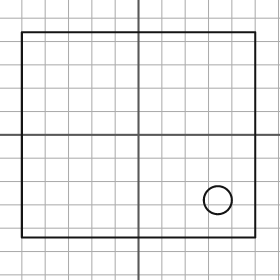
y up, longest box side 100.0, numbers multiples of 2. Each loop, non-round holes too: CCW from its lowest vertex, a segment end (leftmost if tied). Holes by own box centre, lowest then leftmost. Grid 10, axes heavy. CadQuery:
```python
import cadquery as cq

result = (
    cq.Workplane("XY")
    .moveTo(-50.0, -44.0)
    .lineTo(50.0, -44.0)
    .lineTo(50.0, 44.0)
    .lineTo(-50.0, 44.0)
    .close()
    .moveTo(34.0, -28.0)
    .circle(6.0)
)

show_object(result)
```